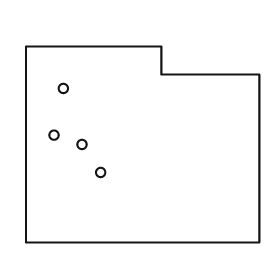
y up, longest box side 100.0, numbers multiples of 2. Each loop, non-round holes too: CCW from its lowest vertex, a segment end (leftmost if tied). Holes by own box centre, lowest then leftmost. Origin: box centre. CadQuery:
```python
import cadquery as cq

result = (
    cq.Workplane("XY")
    .moveTo(-50.0, -42.0)
    .lineTo(50.0, -42.0)
    .lineTo(50.0, 30.0)
    .lineTo(8.0, 30.0)
    .lineTo(8.0, 42.0)
    .lineTo(-50.0, 42.0)
    .close()
    .moveTo(-18.0, -12.0)
    .circle(2.0)
    .moveTo(-26.0, 0.0)
    .circle(2.0)
    .moveTo(-38.0, 4.0)
    .circle(2.0)
    .moveTo(-34.0, 24.0)
    .circle(2.0)
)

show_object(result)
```